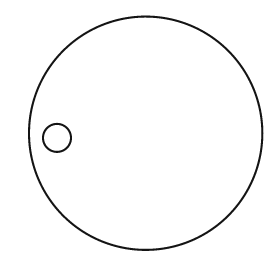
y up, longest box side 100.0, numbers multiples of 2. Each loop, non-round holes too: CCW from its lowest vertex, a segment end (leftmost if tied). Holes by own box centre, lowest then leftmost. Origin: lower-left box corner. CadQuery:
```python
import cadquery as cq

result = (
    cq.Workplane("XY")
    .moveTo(50.0, 50.0)
    .circle(50.0)
    .moveTo(12.0, 48.0)
    .circle(6.0)
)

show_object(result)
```